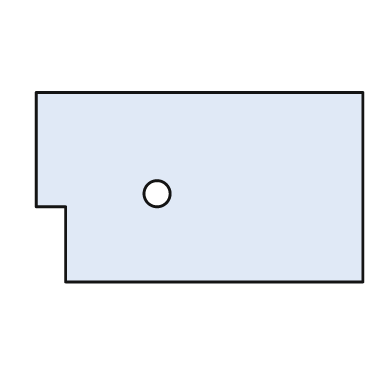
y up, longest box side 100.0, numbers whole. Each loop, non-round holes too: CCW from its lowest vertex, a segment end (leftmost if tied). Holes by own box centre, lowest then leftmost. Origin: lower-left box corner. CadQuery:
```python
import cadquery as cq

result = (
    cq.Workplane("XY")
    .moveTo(9.0, 0.0)
    .lineTo(100.0, 0.0)
    .lineTo(100.0, 58.0)
    .lineTo(0.0, 58.0)
    .lineTo(0.0, 23.0)
    .lineTo(9.0, 23.0)
    .close()
    .moveTo(37.0, 27.0)
    .circle(4.0)
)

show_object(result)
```